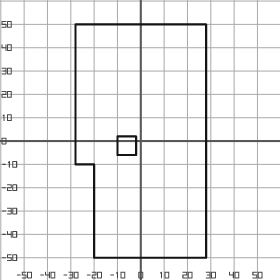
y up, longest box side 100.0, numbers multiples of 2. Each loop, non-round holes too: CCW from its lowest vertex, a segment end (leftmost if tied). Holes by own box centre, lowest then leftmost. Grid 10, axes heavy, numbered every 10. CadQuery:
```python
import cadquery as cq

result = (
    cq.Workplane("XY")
    .moveTo(-20.0, -50.0)
    .lineTo(28.0, -50.0)
    .lineTo(28.0, 50.0)
    .lineTo(-28.0, 50.0)
    .lineTo(-28.0, -10.0)
    .lineTo(-20.0, -10.0)
    .close()
    .moveTo(-10.0, -6.0)
    .lineTo(-2.0, -6.0)
    .lineTo(-2.0, 2.0)
    .lineTo(-10.0, 2.0)
    .close()
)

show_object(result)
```